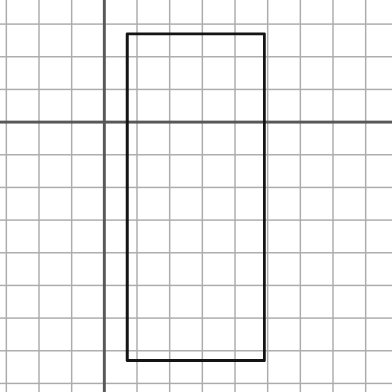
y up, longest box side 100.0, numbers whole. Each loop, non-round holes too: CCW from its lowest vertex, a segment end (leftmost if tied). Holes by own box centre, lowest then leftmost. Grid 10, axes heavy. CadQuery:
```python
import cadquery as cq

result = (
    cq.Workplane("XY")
    .moveTo(7.0, -73.0)
    .lineTo(49.0, -73.0)
    .lineTo(49.0, 27.0)
    .lineTo(7.0, 27.0)
    .close()
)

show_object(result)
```